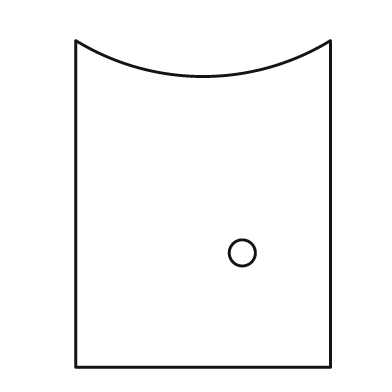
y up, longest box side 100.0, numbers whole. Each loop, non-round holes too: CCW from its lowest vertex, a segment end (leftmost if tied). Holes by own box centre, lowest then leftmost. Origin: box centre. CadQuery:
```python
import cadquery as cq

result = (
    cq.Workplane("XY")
    .moveTo(-39.0, -50.0)
    .lineTo(39.0, -50.0)
    .lineTo(39.0, 50.0)
    .threePointArc((0.0, 39.0), (-39.0, 50.0))
    .close()
    .moveTo(12.0, -15.0)
    .circle(4.0)
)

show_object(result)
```